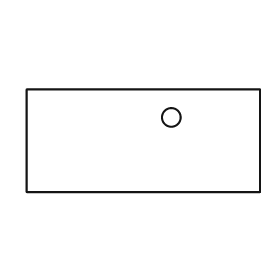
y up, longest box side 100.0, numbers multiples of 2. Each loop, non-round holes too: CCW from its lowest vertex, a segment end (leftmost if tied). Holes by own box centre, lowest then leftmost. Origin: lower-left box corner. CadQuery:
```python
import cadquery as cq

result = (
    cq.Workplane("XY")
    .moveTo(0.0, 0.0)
    .lineTo(100.0, 0.0)
    .lineTo(100.0, 44.0)
    .lineTo(0.0, 44.0)
    .close()
    .moveTo(62.0, 32.0)
    .circle(4.0)
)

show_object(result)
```